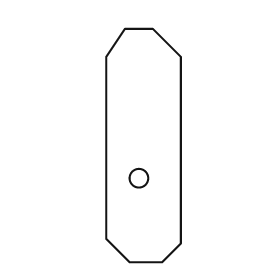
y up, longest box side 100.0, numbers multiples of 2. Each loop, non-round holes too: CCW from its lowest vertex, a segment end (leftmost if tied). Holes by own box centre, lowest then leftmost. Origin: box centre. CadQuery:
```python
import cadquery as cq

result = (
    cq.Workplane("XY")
    .moveTo(-6.0, -50.0)
    .lineTo(8.0, -50.0)
    .lineTo(16.0, -42.0)
    .lineTo(16.0, 38.0)
    .lineTo(4.0, 50.0)
    .lineTo(-8.0, 50.0)
    .lineTo(-16.0, 38.0)
    .lineTo(-16.0, -40.0)
    .close()
    .moveTo(-2.0, -14.0)
    .circle(4.0)
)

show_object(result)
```